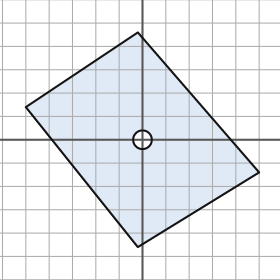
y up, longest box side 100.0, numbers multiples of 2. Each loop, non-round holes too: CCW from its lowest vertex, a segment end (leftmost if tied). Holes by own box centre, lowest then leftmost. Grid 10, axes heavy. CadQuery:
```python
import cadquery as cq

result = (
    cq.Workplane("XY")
    .moveTo(-2.0, -46.0)
    .lineTo(50.0, -14.0)
    .lineTo(-2.0, 46.0)
    .lineTo(-50.0, 14.0)
    .close()
    .moveTo(0.0, 0.0)
    .circle(4.0)
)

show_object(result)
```